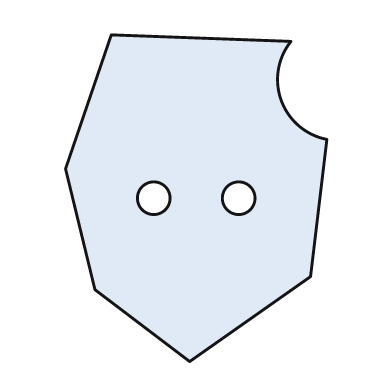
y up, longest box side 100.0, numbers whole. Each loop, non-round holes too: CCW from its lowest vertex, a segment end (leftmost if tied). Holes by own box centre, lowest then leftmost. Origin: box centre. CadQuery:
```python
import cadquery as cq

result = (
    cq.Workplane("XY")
    .moveTo(-2.0, -50.0)
    .lineTo(35.0, -24.0)
    .lineTo(40.0, 18.0)
    .threePointArc((26.0, 30.0), (29.0, 48.0))
    .lineTo(-26.0, 50.0)
    .lineTo(-40.0, 9.0)
    .lineTo(-31.0, -28.0)
    .close()
    .moveTo(-13.0, 0.0)
    .circle(5.0)
    .moveTo(13.0, 0.0)
    .circle(5.0)
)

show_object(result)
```